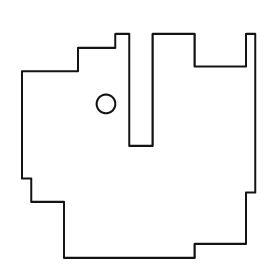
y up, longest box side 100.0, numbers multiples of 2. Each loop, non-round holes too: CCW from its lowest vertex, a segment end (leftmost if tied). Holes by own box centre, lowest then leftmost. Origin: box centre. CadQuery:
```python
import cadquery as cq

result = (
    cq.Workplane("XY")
    .moveTo(-32.0, -48.0)
    .lineTo(24.0, -48.0)
    .lineTo(24.0, -42.0)
    .lineTo(46.0, -42.0)
    .lineTo(46.0, -20.0)
    .lineTo(50.0, -20.0)
    .lineTo(50.0, 48.0)
    .lineTo(46.0, 48.0)
    .lineTo(46.0, 34.0)
    .lineTo(24.0, 34.0)
    .lineTo(24.0, 48.0)
    .lineTo(6.0, 48.0)
    .lineTo(6.0, 0.0)
    .lineTo(-4.0, 0.0)
    .lineTo(-4.0, 48.0)
    .lineTo(-10.0, 48.0)
    .lineTo(-10.0, 42.0)
    .lineTo(-26.0, 42.0)
    .lineTo(-26.0, 32.0)
    .lineTo(-50.0, 32.0)
    .lineTo(-50.0, -14.0)
    .lineTo(-46.0, -14.0)
    .lineTo(-46.0, -24.0)
    .lineTo(-32.0, -24.0)
    .close()
    .moveTo(-14.0, 18.0)
    .circle(4.0)
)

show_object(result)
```